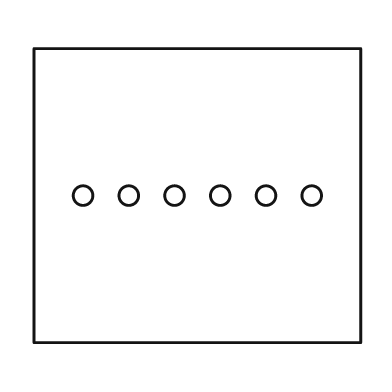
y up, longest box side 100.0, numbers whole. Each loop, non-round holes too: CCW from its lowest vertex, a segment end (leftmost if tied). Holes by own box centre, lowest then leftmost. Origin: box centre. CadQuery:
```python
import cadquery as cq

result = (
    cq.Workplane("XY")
    .moveTo(-50.0, -45.0)
    .lineTo(50.0, -45.0)
    .lineTo(50.0, 45.0)
    .lineTo(-50.0, 45.0)
    .close()
    .moveTo(-35.0, 0.0)
    .circle(3.0)
    .moveTo(-21.0, 0.0)
    .circle(3.0)
    .moveTo(-7.0, 0.0)
    .circle(3.0)
    .moveTo(7.0, 0.0)
    .circle(3.0)
    .moveTo(21.0, 0.0)
    .circle(3.0)
    .moveTo(35.0, 0.0)
    .circle(3.0)
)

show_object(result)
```